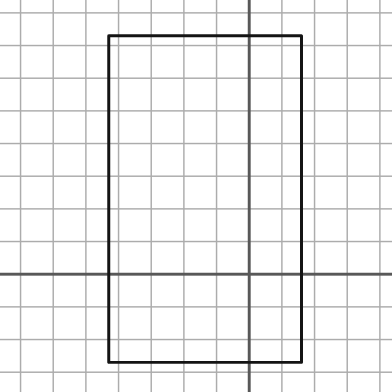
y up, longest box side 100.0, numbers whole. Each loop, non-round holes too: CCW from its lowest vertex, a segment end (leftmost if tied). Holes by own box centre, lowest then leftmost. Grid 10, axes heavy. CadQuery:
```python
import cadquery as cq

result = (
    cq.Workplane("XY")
    .moveTo(-43.0, -27.0)
    .lineTo(16.0, -27.0)
    .lineTo(16.0, 73.0)
    .lineTo(-43.0, 73.0)
    .close()
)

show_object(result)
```